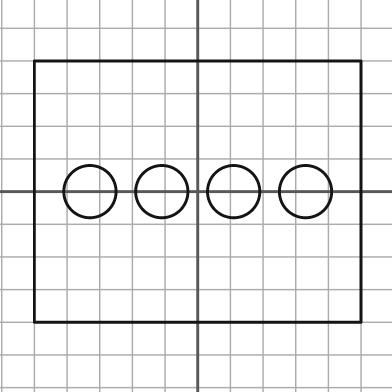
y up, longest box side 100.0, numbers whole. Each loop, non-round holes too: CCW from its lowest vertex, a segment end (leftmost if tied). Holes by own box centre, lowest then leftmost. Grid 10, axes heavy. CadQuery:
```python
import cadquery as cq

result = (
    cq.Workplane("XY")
    .moveTo(-50.0, -40.0)
    .lineTo(50.0, -40.0)
    .lineTo(50.0, 40.0)
    .lineTo(-50.0, 40.0)
    .close()
    .moveTo(-33.0, 0.0)
    .circle(8.0)
    .moveTo(-11.0, 0.0)
    .circle(8.0)
    .moveTo(11.0, 0.0)
    .circle(8.0)
    .moveTo(33.0, 0.0)
    .circle(8.0)
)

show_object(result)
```